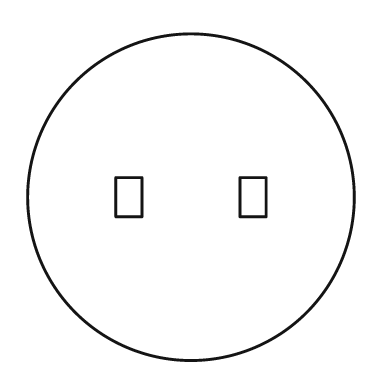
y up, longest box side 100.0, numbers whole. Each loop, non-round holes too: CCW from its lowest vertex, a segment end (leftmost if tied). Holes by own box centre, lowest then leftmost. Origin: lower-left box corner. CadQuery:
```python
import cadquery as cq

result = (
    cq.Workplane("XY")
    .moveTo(50.0, 50.0)
    .circle(50.0)
    .moveTo(27.0, 44.0)
    .lineTo(35.0, 44.0)
    .lineTo(35.0, 56.0)
    .lineTo(27.0, 56.0)
    .close()
    .moveTo(65.0, 44.0)
    .lineTo(73.0, 44.0)
    .lineTo(73.0, 56.0)
    .lineTo(65.0, 56.0)
    .close()
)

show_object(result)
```